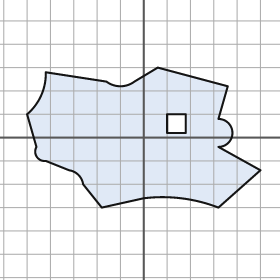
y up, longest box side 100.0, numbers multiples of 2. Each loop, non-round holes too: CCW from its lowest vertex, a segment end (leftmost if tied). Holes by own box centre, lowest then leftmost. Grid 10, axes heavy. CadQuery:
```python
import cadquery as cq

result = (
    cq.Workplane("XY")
    .moveTo(-18.0, -30.0)
    .lineTo(0.0, -26.0)
    .threePointArc((16.0, -26.0), (32.0, -30.0))
    .lineTo(50.0, -14.0)
    .lineTo(32.0, -4.0)
    .threePointArc((38.0, 2.0), (32.0, 8.0))
    .lineTo(36.0, 22.0)
    .lineTo(6.0, 30.0)
    .lineTo(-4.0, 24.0)
    .threePointArc((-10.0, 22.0), (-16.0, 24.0))
    .lineTo(-42.0, 28.0)
    .threePointArc((-44.0, 18.0), (-50.0, 10.0))
    .lineTo(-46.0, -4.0)
    .threePointArc((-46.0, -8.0), (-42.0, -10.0))
    .lineTo(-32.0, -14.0)
    .threePointArc((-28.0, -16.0), (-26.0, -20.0))
    .close()
    .moveTo(10.0, 2.0)
    .lineTo(18.0, 2.0)
    .lineTo(18.0, 10.0)
    .lineTo(10.0, 10.0)
    .close()
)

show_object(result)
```